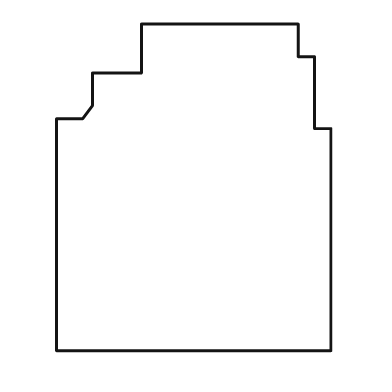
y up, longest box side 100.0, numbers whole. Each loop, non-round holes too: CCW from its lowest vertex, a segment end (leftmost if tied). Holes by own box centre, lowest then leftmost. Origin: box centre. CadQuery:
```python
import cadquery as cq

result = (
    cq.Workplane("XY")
    .moveTo(-42.0, -50.0)
    .lineTo(42.0, -50.0)
    .lineTo(42.0, 18.0)
    .lineTo(37.0, 18.0)
    .lineTo(37.0, 40.0)
    .lineTo(32.0, 40.0)
    .lineTo(32.0, 50.0)
    .lineTo(-16.0, 50.0)
    .lineTo(-16.0, 35.0)
    .lineTo(-31.0, 35.0)
    .lineTo(-31.0, 25.0)
    .lineTo(-34.0, 21.0)
    .lineTo(-42.0, 21.0)
    .close()
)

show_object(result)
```